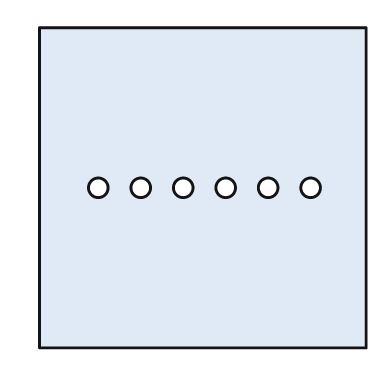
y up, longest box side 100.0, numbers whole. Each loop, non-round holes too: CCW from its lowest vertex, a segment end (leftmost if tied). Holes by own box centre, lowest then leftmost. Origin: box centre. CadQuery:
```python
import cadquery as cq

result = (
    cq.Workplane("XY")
    .moveTo(-50.0, -49.0)
    .lineTo(50.0, -49.0)
    .lineTo(50.0, 49.0)
    .lineTo(-50.0, 49.0)
    .close()
    .moveTo(-32.0, 0.0)
    .circle(3.0)
    .moveTo(-19.0, 0.0)
    .circle(3.0)
    .moveTo(-6.0, 0.0)
    .circle(3.0)
    .moveTo(7.0, 0.0)
    .circle(3.0)
    .moveTo(20.0, 0.0)
    .circle(3.0)
    .moveTo(33.0, 0.0)
    .circle(3.0)
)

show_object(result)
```